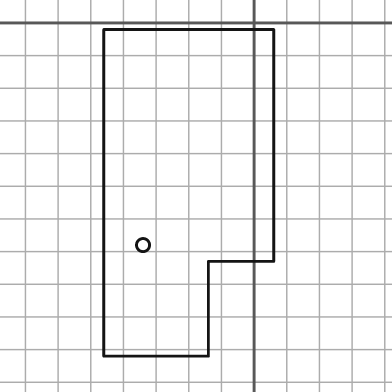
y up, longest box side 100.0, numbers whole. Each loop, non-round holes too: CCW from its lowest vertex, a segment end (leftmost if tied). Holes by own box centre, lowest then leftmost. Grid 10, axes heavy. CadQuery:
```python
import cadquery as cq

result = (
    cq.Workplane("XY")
    .moveTo(-46.0, -102.0)
    .lineTo(-14.0, -102.0)
    .lineTo(-14.0, -73.0)
    .lineTo(6.0, -73.0)
    .lineTo(6.0, -2.0)
    .lineTo(-46.0, -2.0)
    .close()
    .moveTo(-34.0, -68.0)
    .circle(2.0)
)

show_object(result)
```